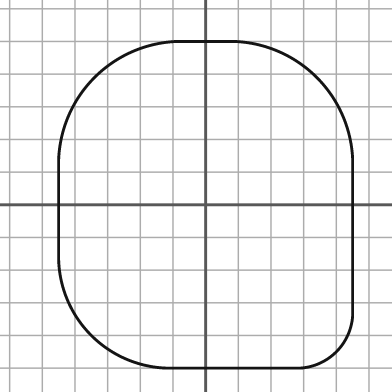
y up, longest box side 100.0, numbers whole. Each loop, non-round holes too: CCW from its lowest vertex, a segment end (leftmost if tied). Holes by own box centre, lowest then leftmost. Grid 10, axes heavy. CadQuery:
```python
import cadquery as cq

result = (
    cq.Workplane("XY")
    .moveTo(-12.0, -50.0)
    .lineTo(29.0, -50.0)
    .threePointArc((40.0, -45.0), (45.0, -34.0))
    .lineTo(45.0, 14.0)
    .threePointArc((34.0, 39.0), (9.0, 50.0))
    .lineTo(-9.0, 50.0)
    .threePointArc((-34.0, 39.0), (-45.0, 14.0))
    .lineTo(-45.0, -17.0)
    .threePointArc((-35.0, -40.0), (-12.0, -50.0))
    .close()
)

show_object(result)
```